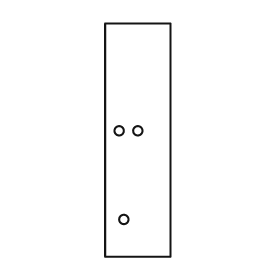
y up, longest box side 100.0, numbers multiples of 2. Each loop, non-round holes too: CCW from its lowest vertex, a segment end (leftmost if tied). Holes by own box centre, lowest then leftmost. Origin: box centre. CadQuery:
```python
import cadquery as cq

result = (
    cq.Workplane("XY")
    .moveTo(-14.0, -50.0)
    .lineTo(14.0, -50.0)
    .lineTo(14.0, 50.0)
    .lineTo(-14.0, 50.0)
    .close()
    .moveTo(-6.0, -34.0)
    .circle(2.0)
    .moveTo(-8.0, 4.0)
    .circle(2.0)
    .moveTo(0.0, 4.0)
    .circle(2.0)
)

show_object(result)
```